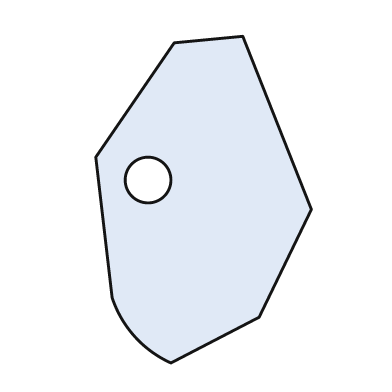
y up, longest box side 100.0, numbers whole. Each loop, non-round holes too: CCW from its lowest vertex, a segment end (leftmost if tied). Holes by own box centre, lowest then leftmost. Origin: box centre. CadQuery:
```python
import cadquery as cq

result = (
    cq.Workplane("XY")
    .moveTo(-10.0, -50.0)
    .lineTo(17.0, -36.0)
    .lineTo(33.0, -3.0)
    .lineTo(12.0, 50.0)
    .lineTo(-9.0, 48.0)
    .lineTo(-33.0, 13.0)
    .lineTo(-28.0, -30.0)
    .threePointArc((-21.0, -42.0), (-10.0, -50.0))
    .close()
    .moveTo(-17.0, 6.0)
    .circle(7.0)
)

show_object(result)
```